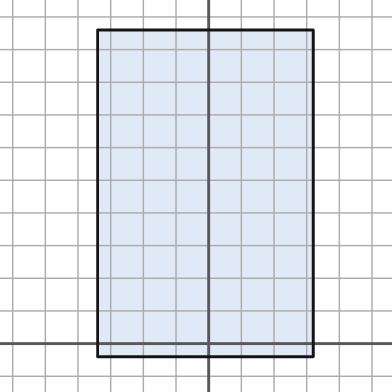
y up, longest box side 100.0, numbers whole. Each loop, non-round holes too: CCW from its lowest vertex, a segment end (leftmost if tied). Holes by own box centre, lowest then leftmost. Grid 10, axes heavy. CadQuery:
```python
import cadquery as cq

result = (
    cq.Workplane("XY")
    .moveTo(-34.0, -4.0)
    .lineTo(32.0, -4.0)
    .lineTo(32.0, 96.0)
    .lineTo(-34.0, 96.0)
    .close()
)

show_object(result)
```